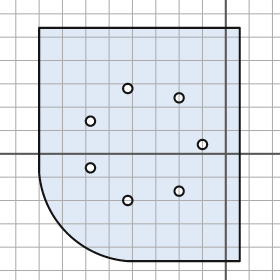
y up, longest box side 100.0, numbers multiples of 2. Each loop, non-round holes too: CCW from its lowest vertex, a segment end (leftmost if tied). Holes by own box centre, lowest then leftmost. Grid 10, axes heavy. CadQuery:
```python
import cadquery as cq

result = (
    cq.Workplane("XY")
    .moveTo(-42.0, -46.0)
    .lineTo(6.0, -46.0)
    .lineTo(6.0, 54.0)
    .lineTo(-80.0, 54.0)
    .lineTo(-80.0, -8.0)
    .threePointArc((-68.0, -34.0), (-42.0, -46.0))
    .close()
    .moveTo(-42.0, -20.0)
    .circle(2.0)
    .moveTo(-20.0, -16.0)
    .circle(2.0)
    .moveTo(-58.0, -6.0)
    .circle(2.0)
    .moveTo(-10.0, 4.0)
    .circle(2.0)
    .moveTo(-58.0, 14.0)
    .circle(2.0)
    .moveTo(-20.0, 24.0)
    .circle(2.0)
    .moveTo(-42.0, 28.0)
    .circle(2.0)
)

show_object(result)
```